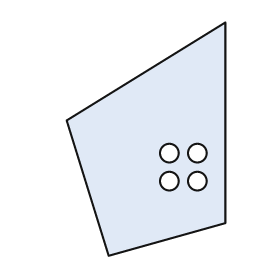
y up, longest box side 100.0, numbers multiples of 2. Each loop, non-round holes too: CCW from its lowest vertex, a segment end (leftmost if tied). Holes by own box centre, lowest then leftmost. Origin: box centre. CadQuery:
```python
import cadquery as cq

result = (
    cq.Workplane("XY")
    .moveTo(-16.0, -50.0)
    .lineTo(34.0, -36.0)
    .lineTo(34.0, 50.0)
    .lineTo(-34.0, 8.0)
    .close()
    .moveTo(10.0, -18.0)
    .circle(4.0)
    .moveTo(22.0, -18.0)
    .circle(4.0)
    .moveTo(10.0, -6.0)
    .circle(4.0)
    .moveTo(22.0, -6.0)
    .circle(4.0)
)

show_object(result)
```